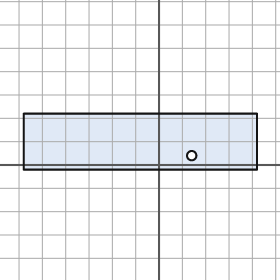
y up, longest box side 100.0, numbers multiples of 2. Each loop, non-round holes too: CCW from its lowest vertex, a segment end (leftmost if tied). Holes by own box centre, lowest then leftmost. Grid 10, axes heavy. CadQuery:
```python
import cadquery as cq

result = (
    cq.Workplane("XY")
    .moveTo(-58.0, -2.0)
    .lineTo(42.0, -2.0)
    .lineTo(42.0, 22.0)
    .lineTo(-58.0, 22.0)
    .close()
    .moveTo(14.0, 4.0)
    .circle(2.0)
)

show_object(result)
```